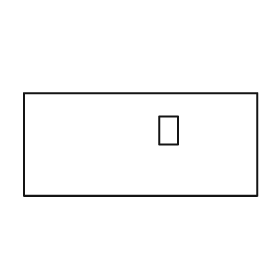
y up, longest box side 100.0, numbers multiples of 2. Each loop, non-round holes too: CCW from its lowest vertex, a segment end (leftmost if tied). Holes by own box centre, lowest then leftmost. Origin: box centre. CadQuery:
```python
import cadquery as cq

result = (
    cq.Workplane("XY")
    .moveTo(-50.0, -22.0)
    .lineTo(50.0, -22.0)
    .lineTo(50.0, 22.0)
    .lineTo(-50.0, 22.0)
    .close()
    .moveTo(8.0, 0.0)
    .lineTo(16.0, 0.0)
    .lineTo(16.0, 12.0)
    .lineTo(8.0, 12.0)
    .close()
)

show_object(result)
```